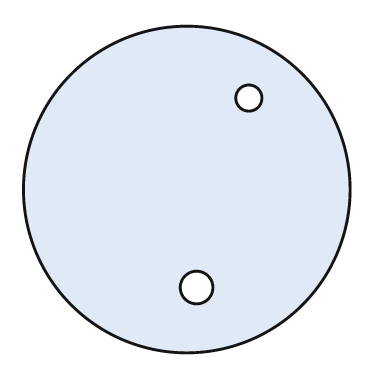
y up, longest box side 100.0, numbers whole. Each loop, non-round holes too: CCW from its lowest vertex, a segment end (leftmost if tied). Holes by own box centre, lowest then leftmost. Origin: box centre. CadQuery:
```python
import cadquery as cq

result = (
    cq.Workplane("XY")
    .moveTo(0.0, 0.0)
    .circle(50.0)
    .moveTo(3.0, -30.0)
    .circle(5.0)
    .moveTo(19.0, 28.0)
    .circle(4.0)
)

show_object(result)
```